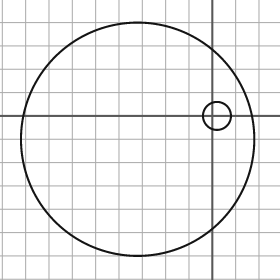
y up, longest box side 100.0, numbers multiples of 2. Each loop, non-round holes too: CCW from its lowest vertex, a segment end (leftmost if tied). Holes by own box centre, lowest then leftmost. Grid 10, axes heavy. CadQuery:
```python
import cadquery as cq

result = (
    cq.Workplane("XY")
    .moveTo(-32.0, -10.0)
    .circle(50.0)
    .moveTo(2.0, 0.0)
    .circle(6.0)
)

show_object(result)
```